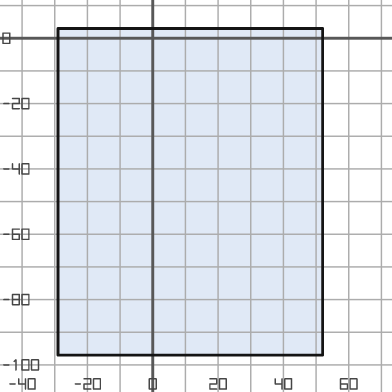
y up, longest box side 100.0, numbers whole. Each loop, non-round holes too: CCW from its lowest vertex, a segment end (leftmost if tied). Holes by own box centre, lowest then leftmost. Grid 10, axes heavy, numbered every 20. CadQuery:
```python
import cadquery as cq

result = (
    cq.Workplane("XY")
    .moveTo(-29.0, -97.0)
    .lineTo(52.0, -97.0)
    .lineTo(52.0, 3.0)
    .lineTo(-29.0, 3.0)
    .close()
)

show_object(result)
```